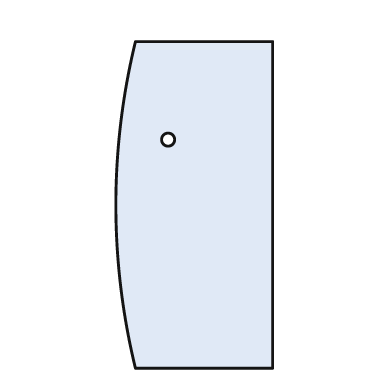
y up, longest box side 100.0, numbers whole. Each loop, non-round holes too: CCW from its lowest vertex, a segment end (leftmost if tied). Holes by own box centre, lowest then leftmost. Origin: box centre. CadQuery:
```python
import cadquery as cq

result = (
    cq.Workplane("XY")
    .moveTo(-18.0, -50.0)
    .lineTo(24.0, -50.0)
    .lineTo(24.0, 50.0)
    .lineTo(-18.0, 50.0)
    .threePointArc((-24.0, 0.0), (-18.0, -50.0))
    .close()
    .moveTo(-8.0, 20.0)
    .circle(2.0)
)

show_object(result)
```